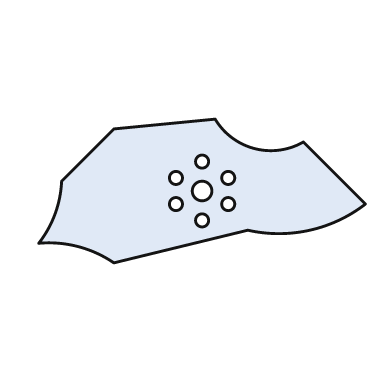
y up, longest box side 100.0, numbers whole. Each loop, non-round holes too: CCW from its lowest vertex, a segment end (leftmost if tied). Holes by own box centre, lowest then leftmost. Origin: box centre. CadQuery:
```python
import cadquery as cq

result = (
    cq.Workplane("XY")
    .moveTo(-27.0, -22.0)
    .lineTo(14.0, -12.0)
    .threePointArc((33.0, -12.0), (50.0, -4.0))
    .lineTo(31.0, 15.0)
    .threePointArc((16.0, 13.0), (4.0, 22.0))
    .lineTo(-27.0, 19.0)
    .lineTo(-43.0, 3.0)
    .threePointArc((-45.0, -7.0), (-50.0, -16.0))
    .threePointArc((-38.0, -17.0), (-27.0, -22.0))
    .close()
    .moveTo(0.0, -9.0)
    .circle(2.0)
    .moveTo(-8.0, -4.0)
    .circle(2.0)
    .moveTo(8.0, -4.0)
    .circle(2.0)
    .moveTo(0.0, 0.0)
    .circle(3.0)
    .moveTo(-8.0, 4.0)
    .circle(2.0)
    .moveTo(8.0, 4.0)
    .circle(2.0)
    .moveTo(0.0, 9.0)
    .circle(2.0)
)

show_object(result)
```